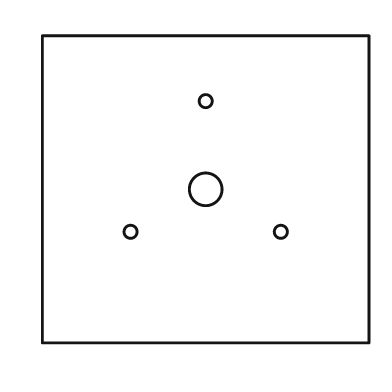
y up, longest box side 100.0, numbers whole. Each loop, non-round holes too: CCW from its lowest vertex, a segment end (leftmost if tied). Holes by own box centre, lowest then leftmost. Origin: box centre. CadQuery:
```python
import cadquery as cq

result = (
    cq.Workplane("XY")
    .moveTo(-50.0, -47.0)
    .lineTo(50.0, -47.0)
    .lineTo(50.0, 47.0)
    .lineTo(-50.0, 47.0)
    .close()
    .moveTo(-23.0, -13.0)
    .circle(2.0)
    .moveTo(23.0, -13.0)
    .circle(2.0)
    .moveTo(0.0, 0.0)
    .circle(5.0)
    .moveTo(0.0, 27.0)
    .circle(2.0)
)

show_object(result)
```